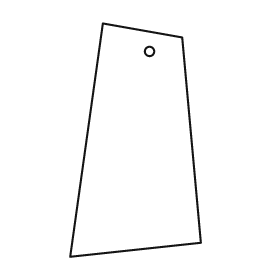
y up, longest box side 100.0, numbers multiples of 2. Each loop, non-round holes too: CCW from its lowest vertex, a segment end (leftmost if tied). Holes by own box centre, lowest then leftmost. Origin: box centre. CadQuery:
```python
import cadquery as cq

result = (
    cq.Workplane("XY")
    .moveTo(-28.0, -50.0)
    .lineTo(28.0, -44.0)
    .lineTo(20.0, 44.0)
    .lineTo(-14.0, 50.0)
    .close()
    .moveTo(6.0, 38.0)
    .circle(2.0)
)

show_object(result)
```